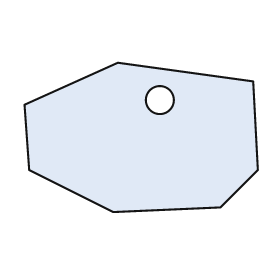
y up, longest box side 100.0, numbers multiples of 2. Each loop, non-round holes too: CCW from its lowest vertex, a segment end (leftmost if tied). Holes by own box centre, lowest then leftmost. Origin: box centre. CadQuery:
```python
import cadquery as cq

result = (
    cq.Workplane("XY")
    .moveTo(-12.0, -32.0)
    .lineTo(34.0, -30.0)
    .lineTo(50.0, -14.0)
    .lineTo(48.0, 24.0)
    .lineTo(-10.0, 32.0)
    .lineTo(-50.0, 14.0)
    .lineTo(-48.0, -14.0)
    .close()
    .moveTo(8.0, 16.0)
    .circle(6.0)
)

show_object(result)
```